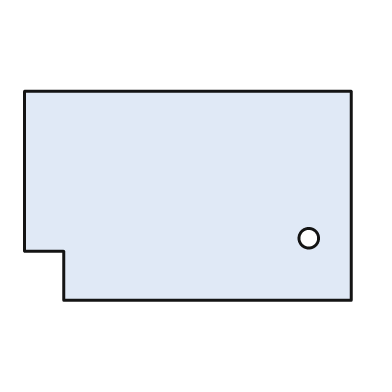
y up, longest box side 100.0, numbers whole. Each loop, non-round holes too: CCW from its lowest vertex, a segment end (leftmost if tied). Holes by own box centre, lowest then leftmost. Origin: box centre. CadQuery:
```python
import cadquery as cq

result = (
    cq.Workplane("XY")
    .moveTo(-38.0, -32.0)
    .lineTo(50.0, -32.0)
    .lineTo(50.0, 32.0)
    .lineTo(-50.0, 32.0)
    .lineTo(-50.0, -17.0)
    .lineTo(-38.0, -17.0)
    .close()
    .moveTo(37.0, -13.0)
    .circle(3.0)
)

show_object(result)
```